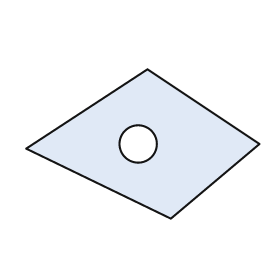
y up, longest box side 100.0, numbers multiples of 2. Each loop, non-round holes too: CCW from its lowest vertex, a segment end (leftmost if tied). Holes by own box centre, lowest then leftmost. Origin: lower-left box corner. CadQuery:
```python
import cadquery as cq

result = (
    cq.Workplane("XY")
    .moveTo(62.0, 0.0)
    .lineTo(100.0, 32.0)
    .lineTo(52.0, 64.0)
    .lineTo(0.0, 30.0)
    .close()
    .moveTo(48.0, 32.0)
    .circle(8.0)
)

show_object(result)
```